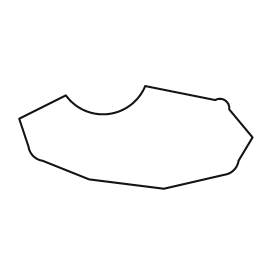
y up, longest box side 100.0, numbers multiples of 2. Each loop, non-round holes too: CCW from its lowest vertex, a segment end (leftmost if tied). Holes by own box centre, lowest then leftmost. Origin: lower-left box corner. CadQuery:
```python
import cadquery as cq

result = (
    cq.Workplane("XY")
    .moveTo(62.0, 0.0)
    .lineTo(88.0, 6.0)
    .threePointArc((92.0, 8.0), (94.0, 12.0))
    .lineTo(100.0, 22.0)
    .lineTo(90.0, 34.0)
    .threePointArc((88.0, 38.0), (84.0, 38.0))
    .lineTo(54.0, 44.0)
    .threePointArc((38.0, 32.0), (20.0, 40.0))
    .lineTo(0.0, 30.0)
    .lineTo(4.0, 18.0)
    .threePointArc((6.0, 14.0), (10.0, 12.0))
    .lineTo(30.0, 4.0)
    .close()
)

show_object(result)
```